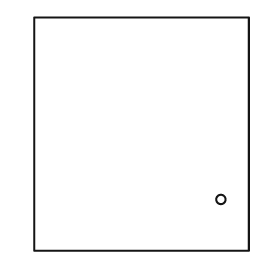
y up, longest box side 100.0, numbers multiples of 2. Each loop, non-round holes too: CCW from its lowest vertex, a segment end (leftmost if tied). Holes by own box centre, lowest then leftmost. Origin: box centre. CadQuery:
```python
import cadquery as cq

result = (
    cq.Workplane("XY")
    .moveTo(-46.0, -50.0)
    .lineTo(46.0, -50.0)
    .lineTo(46.0, 50.0)
    .lineTo(-46.0, 50.0)
    .close()
    .moveTo(34.0, -28.0)
    .circle(2.0)
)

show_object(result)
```